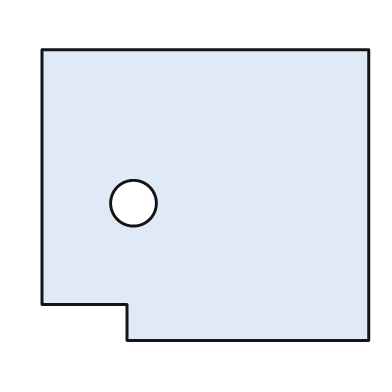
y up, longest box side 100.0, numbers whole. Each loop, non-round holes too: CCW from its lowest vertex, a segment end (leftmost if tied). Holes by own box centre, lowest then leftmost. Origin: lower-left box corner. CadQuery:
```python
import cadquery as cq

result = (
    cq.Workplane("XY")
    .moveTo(26.0, 0.0)
    .lineTo(100.0, 0.0)
    .lineTo(100.0, 89.0)
    .lineTo(0.0, 89.0)
    .lineTo(0.0, 11.0)
    .lineTo(26.0, 11.0)
    .close()
    .moveTo(28.0, 42.0)
    .circle(7.0)
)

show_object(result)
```